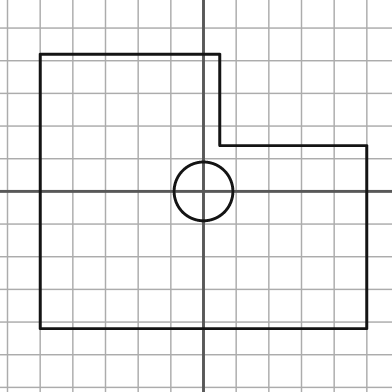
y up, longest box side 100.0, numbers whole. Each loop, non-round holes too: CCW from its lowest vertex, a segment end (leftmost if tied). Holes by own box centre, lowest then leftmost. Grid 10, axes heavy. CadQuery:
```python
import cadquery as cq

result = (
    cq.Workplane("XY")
    .moveTo(-50.0, -42.0)
    .lineTo(50.0, -42.0)
    .lineTo(50.0, 14.0)
    .lineTo(5.0, 14.0)
    .lineTo(5.0, 42.0)
    .lineTo(-50.0, 42.0)
    .close()
    .moveTo(0.0, 0.0)
    .circle(9.0)
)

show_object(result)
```